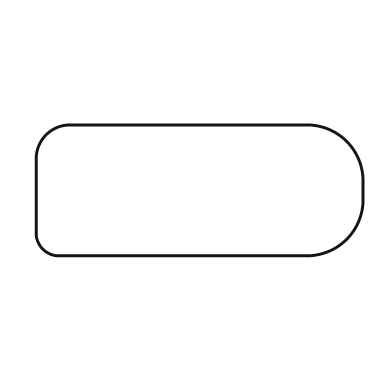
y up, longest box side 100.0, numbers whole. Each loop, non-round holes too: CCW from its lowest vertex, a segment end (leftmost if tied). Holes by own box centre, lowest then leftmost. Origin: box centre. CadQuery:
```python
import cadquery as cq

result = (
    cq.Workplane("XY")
    .moveTo(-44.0, -20.0)
    .lineTo(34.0, -20.0)
    .threePointArc((45.0, -15.0), (50.0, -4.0))
    .lineTo(50.0, 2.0)
    .threePointArc((45.0, 15.0), (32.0, 20.0))
    .lineTo(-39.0, 20.0)
    .threePointArc((-47.0, 17.0), (-50.0, 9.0))
    .lineTo(-50.0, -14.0)
    .threePointArc((-48.0, -18.0), (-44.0, -20.0))
    .close()
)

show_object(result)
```